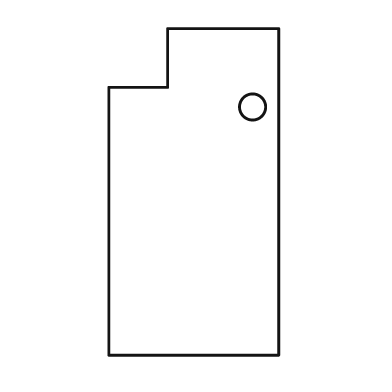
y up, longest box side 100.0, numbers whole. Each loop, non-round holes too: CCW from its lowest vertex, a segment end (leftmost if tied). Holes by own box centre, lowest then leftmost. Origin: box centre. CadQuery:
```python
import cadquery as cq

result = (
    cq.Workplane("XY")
    .moveTo(-26.0, -50.0)
    .lineTo(26.0, -50.0)
    .lineTo(26.0, 50.0)
    .lineTo(-8.0, 50.0)
    .lineTo(-8.0, 32.0)
    .lineTo(-26.0, 32.0)
    .close()
    .moveTo(18.0, 26.0)
    .circle(4.0)
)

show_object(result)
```